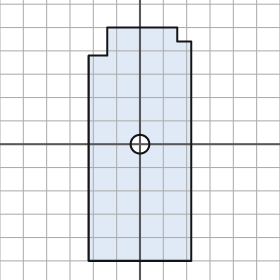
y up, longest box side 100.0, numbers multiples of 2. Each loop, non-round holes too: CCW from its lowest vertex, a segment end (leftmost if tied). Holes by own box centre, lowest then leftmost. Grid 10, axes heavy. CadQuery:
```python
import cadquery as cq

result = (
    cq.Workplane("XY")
    .moveTo(-22.0, -50.0)
    .lineTo(22.0, -50.0)
    .lineTo(22.0, 44.0)
    .lineTo(16.0, 44.0)
    .lineTo(16.0, 50.0)
    .lineTo(-14.0, 50.0)
    .lineTo(-14.0, 38.0)
    .lineTo(-22.0, 38.0)
    .close()
    .moveTo(0.0, 0.0)
    .circle(4.0)
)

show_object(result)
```